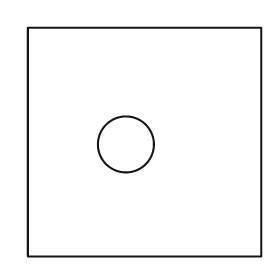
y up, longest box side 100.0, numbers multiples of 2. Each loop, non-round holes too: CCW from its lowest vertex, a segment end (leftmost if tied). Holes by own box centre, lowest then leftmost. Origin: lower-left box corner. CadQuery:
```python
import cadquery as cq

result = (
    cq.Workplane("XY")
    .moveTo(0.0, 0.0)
    .lineTo(100.0, 0.0)
    .lineTo(100.0, 98.0)
    .lineTo(0.0, 98.0)
    .close()
    .moveTo(42.0, 48.0)
    .circle(12.0)
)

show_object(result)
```